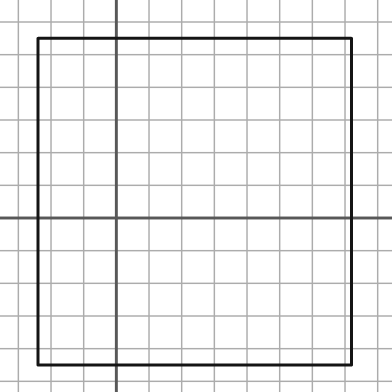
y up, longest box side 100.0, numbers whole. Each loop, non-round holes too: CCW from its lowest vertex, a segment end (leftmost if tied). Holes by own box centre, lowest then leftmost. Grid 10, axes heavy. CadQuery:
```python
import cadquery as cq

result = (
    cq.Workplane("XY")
    .moveTo(-24.0, -45.0)
    .lineTo(72.0, -45.0)
    .lineTo(72.0, 55.0)
    .lineTo(-24.0, 55.0)
    .close()
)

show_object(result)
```